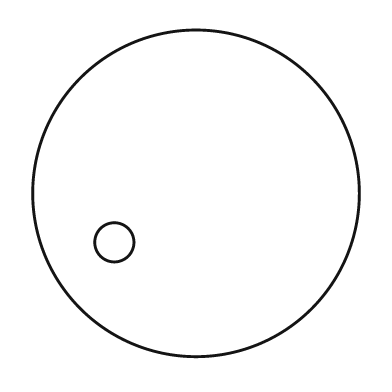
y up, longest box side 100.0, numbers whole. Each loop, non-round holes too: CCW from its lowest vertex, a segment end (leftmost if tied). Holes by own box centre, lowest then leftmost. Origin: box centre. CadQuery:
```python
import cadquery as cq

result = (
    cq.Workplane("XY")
    .moveTo(0.0, 0.0)
    .circle(50.0)
    .moveTo(-25.0, -15.0)
    .circle(6.0)
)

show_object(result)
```